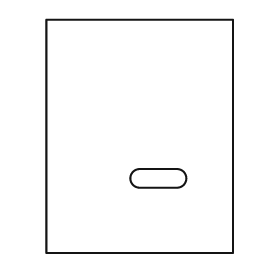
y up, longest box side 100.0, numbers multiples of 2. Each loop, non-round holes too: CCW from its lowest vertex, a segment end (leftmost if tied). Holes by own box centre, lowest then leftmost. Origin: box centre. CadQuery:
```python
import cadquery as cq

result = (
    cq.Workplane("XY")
    .moveTo(-40.0, -50.0)
    .lineTo(40.0, -50.0)
    .lineTo(40.0, 50.0)
    .lineTo(-40.0, 50.0)
    .close()
    .moveTo(0.0, -22.0)
    .lineTo(16.0, -22.0)
    .threePointArc((20.0, -18.0), (16.0, -14.0))
    .lineTo(0.0, -14.0)
    .threePointArc((-4.0, -18.0), (0.0, -22.0))
    .close()
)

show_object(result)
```